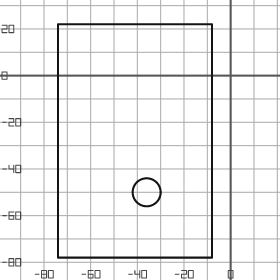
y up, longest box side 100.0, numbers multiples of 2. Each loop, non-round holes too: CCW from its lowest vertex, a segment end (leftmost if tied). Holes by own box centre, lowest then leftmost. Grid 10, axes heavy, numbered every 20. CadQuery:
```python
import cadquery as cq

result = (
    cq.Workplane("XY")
    .moveTo(-74.0, -78.0)
    .lineTo(-8.0, -78.0)
    .lineTo(-8.0, 22.0)
    .lineTo(-74.0, 22.0)
    .close()
    .moveTo(-36.0, -50.0)
    .circle(6.0)
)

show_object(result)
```